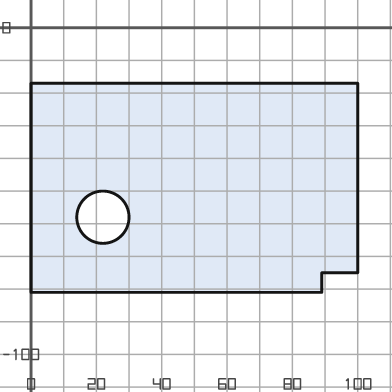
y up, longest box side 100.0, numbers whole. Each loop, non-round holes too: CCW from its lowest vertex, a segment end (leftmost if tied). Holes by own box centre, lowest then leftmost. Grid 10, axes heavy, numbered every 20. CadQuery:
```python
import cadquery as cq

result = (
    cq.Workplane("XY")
    .moveTo(0.0, -81.0)
    .lineTo(89.0, -81.0)
    .lineTo(89.0, -75.0)
    .lineTo(100.0, -75.0)
    .lineTo(100.0, -17.0)
    .lineTo(0.0, -17.0)
    .close()
    .moveTo(22.0, -58.0)
    .circle(8.0)
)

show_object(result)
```